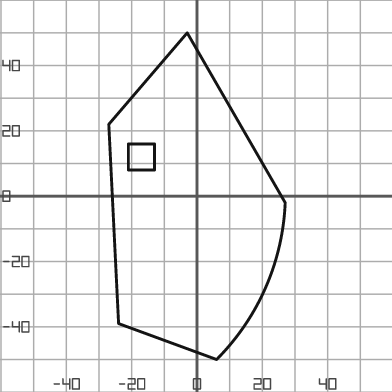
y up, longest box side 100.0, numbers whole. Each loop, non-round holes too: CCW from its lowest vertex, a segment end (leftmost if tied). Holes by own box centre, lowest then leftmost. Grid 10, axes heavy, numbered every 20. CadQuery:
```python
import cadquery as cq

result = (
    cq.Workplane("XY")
    .moveTo(6.0, -50.0)
    .threePointArc((21.0, -28.0), (27.0, -2.0))
    .lineTo(-3.0, 50.0)
    .lineTo(-27.0, 22.0)
    .lineTo(-24.0, -39.0)
    .close()
    .moveTo(-21.0, 8.0)
    .lineTo(-13.0, 8.0)
    .lineTo(-13.0, 16.0)
    .lineTo(-21.0, 16.0)
    .close()
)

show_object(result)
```